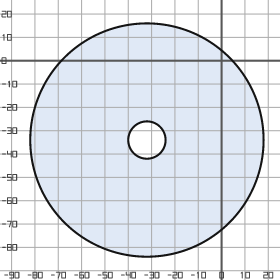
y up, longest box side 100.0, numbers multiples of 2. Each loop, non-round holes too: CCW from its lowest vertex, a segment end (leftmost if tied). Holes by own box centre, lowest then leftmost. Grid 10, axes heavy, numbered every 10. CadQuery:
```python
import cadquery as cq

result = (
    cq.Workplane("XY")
    .moveTo(-32.0, -34.0)
    .circle(50.0)
    .moveTo(-32.0, -34.0)
    .circle(8.0)
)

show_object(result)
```